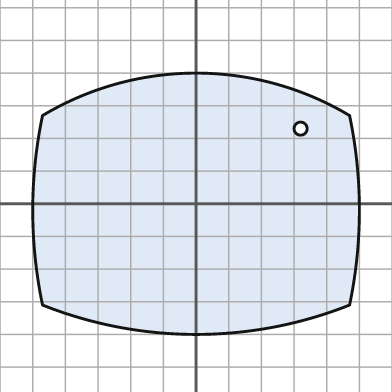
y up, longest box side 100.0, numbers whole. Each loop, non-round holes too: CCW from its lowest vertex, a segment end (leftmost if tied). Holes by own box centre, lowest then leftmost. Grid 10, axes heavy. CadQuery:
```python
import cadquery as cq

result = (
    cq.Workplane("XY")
    .moveTo(-47.0, -31.0)
    .threePointArc((0.0, -40.0), (47.0, -31.0))
    .threePointArc((50.0, -2.0), (47.0, 27.0))
    .threePointArc((0.0, 40.0), (-47.0, 27.0))
    .threePointArc((-50.0, -2.0), (-47.0, -31.0))
    .close()
    .moveTo(32.0, 23.0)
    .circle(2.0)
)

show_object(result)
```